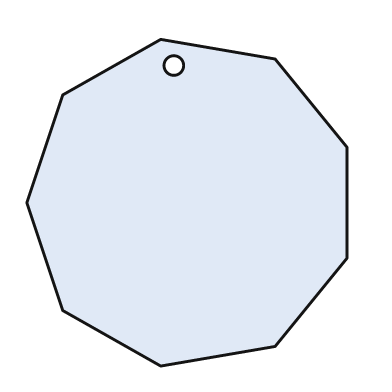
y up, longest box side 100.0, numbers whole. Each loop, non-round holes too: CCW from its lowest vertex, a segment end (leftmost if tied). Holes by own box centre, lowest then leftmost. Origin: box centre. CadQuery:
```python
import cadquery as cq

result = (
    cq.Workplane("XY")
    .moveTo(-8.0, -50.0)
    .lineTo(27.0, -44.0)
    .lineTo(49.0, -17.0)
    .lineTo(49.0, 17.0)
    .lineTo(27.0, 44.0)
    .lineTo(-8.0, 50.0)
    .lineTo(-38.0, 33.0)
    .lineTo(-49.0, 0.0)
    .lineTo(-38.0, -33.0)
    .close()
    .moveTo(-4.0, 42.0)
    .circle(3.0)
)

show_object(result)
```